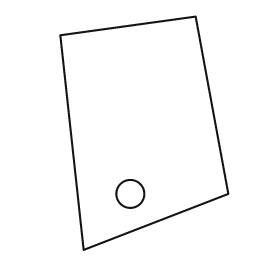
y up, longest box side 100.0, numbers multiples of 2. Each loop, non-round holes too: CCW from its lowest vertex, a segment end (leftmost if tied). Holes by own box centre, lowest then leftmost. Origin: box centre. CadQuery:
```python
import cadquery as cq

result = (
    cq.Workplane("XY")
    .moveTo(-26.0, -50.0)
    .lineTo(36.0, -26.0)
    .lineTo(22.0, 50.0)
    .lineTo(-36.0, 42.0)
    .close()
    .moveTo(-6.0, -26.0)
    .circle(6.0)
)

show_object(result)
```